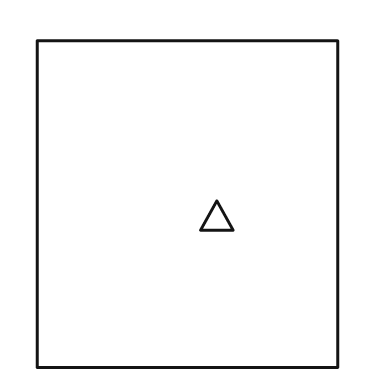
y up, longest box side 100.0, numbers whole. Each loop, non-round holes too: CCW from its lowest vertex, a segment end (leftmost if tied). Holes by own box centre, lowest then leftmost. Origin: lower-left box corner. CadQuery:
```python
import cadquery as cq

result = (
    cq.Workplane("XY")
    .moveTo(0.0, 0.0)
    .lineTo(92.0, 0.0)
    .lineTo(92.0, 100.0)
    .lineTo(0.0, 100.0)
    .close()
    .moveTo(50.0, 42.0)
    .lineTo(60.0, 42.0)
    .lineTo(55.0, 51.0)
    .close()
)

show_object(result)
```